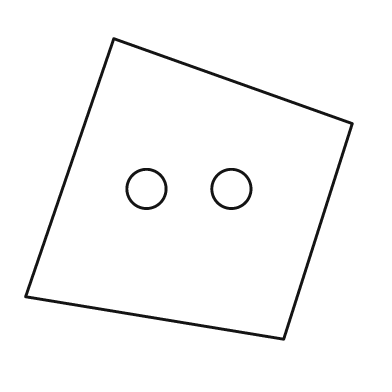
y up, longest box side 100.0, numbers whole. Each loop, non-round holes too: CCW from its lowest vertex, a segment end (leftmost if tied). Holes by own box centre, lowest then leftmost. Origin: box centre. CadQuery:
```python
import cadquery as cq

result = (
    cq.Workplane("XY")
    .moveTo(29.0, -46.0)
    .lineTo(50.0, 20.0)
    .lineTo(-23.0, 46.0)
    .lineTo(-50.0, -33.0)
    .close()
    .moveTo(-13.0, 0.0)
    .circle(6.0)
    .moveTo(13.0, 0.0)
    .circle(6.0)
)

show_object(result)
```